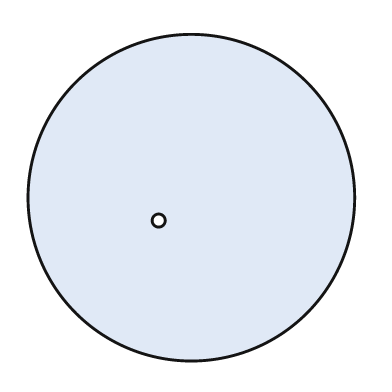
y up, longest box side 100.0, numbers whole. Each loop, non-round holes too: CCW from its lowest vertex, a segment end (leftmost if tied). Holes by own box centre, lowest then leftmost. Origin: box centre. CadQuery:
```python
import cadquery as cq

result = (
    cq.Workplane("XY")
    .moveTo(0.0, 0.0)
    .circle(50.0)
    .moveTo(-10.0, -7.0)
    .circle(2.0)
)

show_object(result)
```